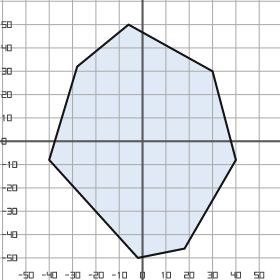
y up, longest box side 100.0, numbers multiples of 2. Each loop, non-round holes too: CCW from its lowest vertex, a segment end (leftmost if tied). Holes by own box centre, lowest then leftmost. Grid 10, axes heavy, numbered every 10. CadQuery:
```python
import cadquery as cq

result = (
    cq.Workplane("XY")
    .moveTo(-2.0, -50.0)
    .lineTo(18.0, -46.0)
    .lineTo(40.0, -8.0)
    .lineTo(30.0, 30.0)
    .lineTo(-6.0, 50.0)
    .lineTo(-28.0, 32.0)
    .lineTo(-40.0, -8.0)
    .close()
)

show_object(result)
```